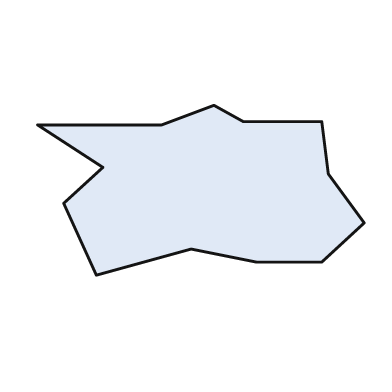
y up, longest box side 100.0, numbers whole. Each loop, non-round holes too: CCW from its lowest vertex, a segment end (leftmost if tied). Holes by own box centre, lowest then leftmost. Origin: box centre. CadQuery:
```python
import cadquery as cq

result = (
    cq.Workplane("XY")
    .moveTo(-32.0, -26.0)
    .lineTo(-3.0, -18.0)
    .lineTo(17.0, -22.0)
    .lineTo(37.0, -22.0)
    .lineTo(50.0, -10.0)
    .lineTo(39.0, 5.0)
    .lineTo(37.0, 21.0)
    .lineTo(13.0, 21.0)
    .lineTo(4.0, 26.0)
    .lineTo(-12.0, 20.0)
    .lineTo(-50.0, 20.0)
    .lineTo(-30.0, 7.0)
    .lineTo(-42.0, -4.0)
    .close()
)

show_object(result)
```